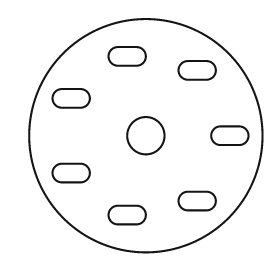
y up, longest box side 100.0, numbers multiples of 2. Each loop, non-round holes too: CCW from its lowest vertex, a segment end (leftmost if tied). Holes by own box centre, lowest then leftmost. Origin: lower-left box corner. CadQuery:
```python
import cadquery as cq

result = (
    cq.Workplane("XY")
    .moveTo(50.0, 50.0)
    .circle(50.0)
    .moveTo(38.0, 12.0)
    .lineTo(46.0, 12.0)
    .threePointArc((50.0, 16.0), (46.0, 20.0))
    .lineTo(38.0, 20.0)
    .threePointArc((34.0, 16.0), (38.0, 12.0))
    .close()
    .moveTo(68.0, 18.0)
    .lineTo(76.0, 18.0)
    .threePointArc((80.0, 22.0), (76.0, 26.0))
    .lineTo(68.0, 26.0)
    .threePointArc((64.0, 22.0), (68.0, 18.0))
    .close()
    .moveTo(14.0, 30.0)
    .lineTo(22.0, 30.0)
    .threePointArc((26.0, 34.0), (22.0, 38.0))
    .lineTo(14.0, 38.0)
    .threePointArc((10.0, 34.0), (14.0, 30.0))
    .close()
    .moveTo(50.0, 50.0)
    .circle(8.0)
    .moveTo(82.0, 46.0)
    .lineTo(90.0, 46.0)
    .threePointArc((94.0, 50.0), (90.0, 54.0))
    .lineTo(82.0, 54.0)
    .threePointArc((78.0, 50.0), (82.0, 46.0))
    .close()
    .moveTo(14.0, 62.0)
    .lineTo(22.0, 62.0)
    .threePointArc((26.0, 66.0), (22.0, 70.0))
    .lineTo(14.0, 70.0)
    .threePointArc((10.0, 66.0), (14.0, 62.0))
    .close()
    .moveTo(68.0, 74.0)
    .lineTo(76.0, 74.0)
    .threePointArc((80.0, 78.0), (76.0, 82.0))
    .lineTo(68.0, 82.0)
    .threePointArc((64.0, 78.0), (68.0, 74.0))
    .close()
    .moveTo(38.0, 80.0)
    .lineTo(46.0, 80.0)
    .threePointArc((50.0, 84.0), (46.0, 88.0))
    .lineTo(38.0, 88.0)
    .threePointArc((34.0, 84.0), (38.0, 80.0))
    .close()
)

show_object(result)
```